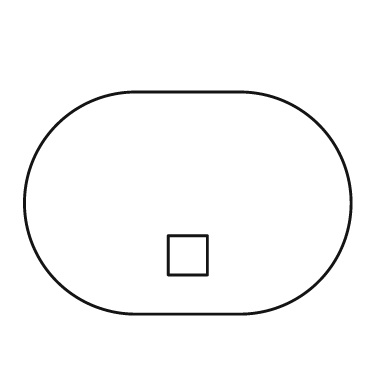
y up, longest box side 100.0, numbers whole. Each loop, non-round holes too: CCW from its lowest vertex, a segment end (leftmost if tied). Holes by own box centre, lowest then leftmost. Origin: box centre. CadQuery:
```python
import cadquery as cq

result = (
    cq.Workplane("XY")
    .moveTo(-16.0, -34.0)
    .lineTo(16.0, -34.0)
    .threePointArc((50.0, 0.0), (16.0, 34.0))
    .lineTo(-16.0, 34.0)
    .threePointArc((-50.0, 0.0), (-16.0, -34.0))
    .close()
    .moveTo(-6.0, -22.0)
    .lineTo(6.0, -22.0)
    .lineTo(6.0, -10.0)
    .lineTo(-6.0, -10.0)
    .close()
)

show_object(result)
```